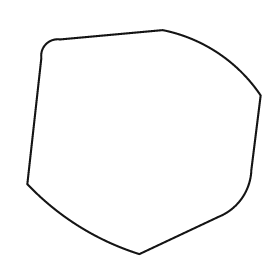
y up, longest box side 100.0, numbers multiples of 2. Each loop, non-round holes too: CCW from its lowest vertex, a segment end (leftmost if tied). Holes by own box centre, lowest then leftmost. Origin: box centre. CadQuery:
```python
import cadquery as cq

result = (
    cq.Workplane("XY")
    .moveTo(-2.0, -48.0)
    .lineTo(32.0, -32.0)
    .threePointArc((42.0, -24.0), (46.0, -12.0))
    .lineTo(50.0, 20.0)
    .threePointArc((32.0, 38.0), (8.0, 48.0))
    .lineTo(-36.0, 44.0)
    .threePointArc((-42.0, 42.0), (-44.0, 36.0))
    .lineTo(-50.0, -18.0)
    .threePointArc((-28.0, -36.0), (-2.0, -48.0))
    .close()
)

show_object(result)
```